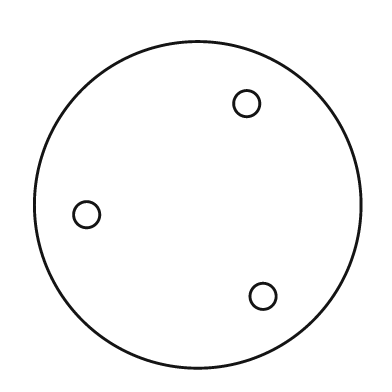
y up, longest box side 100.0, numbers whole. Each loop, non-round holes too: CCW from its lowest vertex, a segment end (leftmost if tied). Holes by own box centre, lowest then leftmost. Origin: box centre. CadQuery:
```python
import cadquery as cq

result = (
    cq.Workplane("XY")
    .moveTo(0.0, 0.0)
    .circle(50.0)
    .moveTo(20.0, -28.0)
    .circle(4.0)
    .moveTo(-34.0, -3.0)
    .circle(4.0)
    .moveTo(15.0, 31.0)
    .circle(4.0)
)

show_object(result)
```